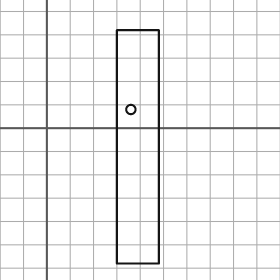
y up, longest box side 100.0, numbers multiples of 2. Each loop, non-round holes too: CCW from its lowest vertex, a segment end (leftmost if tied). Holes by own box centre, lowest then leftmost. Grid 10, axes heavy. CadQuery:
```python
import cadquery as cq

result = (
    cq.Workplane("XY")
    .moveTo(30.0, -58.0)
    .lineTo(48.0, -58.0)
    .lineTo(48.0, 42.0)
    .lineTo(30.0, 42.0)
    .close()
    .moveTo(36.0, 8.0)
    .circle(2.0)
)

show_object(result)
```